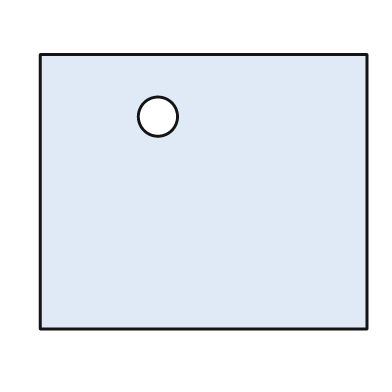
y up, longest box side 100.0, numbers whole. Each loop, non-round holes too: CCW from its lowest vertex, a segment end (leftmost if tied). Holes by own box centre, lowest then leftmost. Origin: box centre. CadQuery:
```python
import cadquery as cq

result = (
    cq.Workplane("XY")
    .moveTo(-50.0, -42.0)
    .lineTo(50.0, -42.0)
    .lineTo(50.0, 42.0)
    .lineTo(-50.0, 42.0)
    .close()
    .moveTo(-14.0, 23.0)
    .circle(6.0)
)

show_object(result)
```